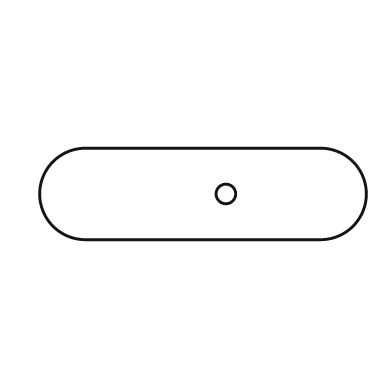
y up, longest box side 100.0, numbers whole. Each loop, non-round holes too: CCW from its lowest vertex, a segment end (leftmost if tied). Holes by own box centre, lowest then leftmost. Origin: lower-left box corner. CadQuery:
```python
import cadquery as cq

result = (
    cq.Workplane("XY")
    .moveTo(14.0, 0.0)
    .lineTo(86.0, 0.0)
    .threePointArc((100.0, 14.0), (86.0, 28.0))
    .lineTo(14.0, 28.0)
    .threePointArc((0.0, 14.0), (14.0, 0.0))
    .close()
    .moveTo(57.0, 14.0)
    .circle(3.0)
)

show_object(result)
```